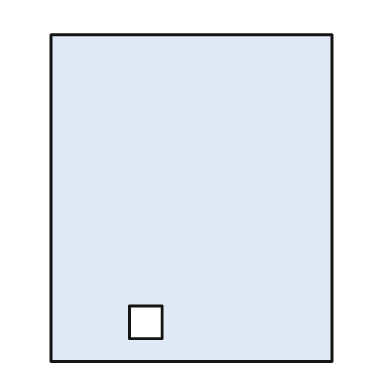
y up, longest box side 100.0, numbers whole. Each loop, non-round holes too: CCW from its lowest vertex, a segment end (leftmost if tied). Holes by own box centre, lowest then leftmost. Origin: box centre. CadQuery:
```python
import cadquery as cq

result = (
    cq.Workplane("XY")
    .moveTo(-43.0, -50.0)
    .lineTo(43.0, -50.0)
    .lineTo(43.0, 50.0)
    .lineTo(-43.0, 50.0)
    .close()
    .moveTo(-19.0, -43.0)
    .lineTo(-9.0, -43.0)
    .lineTo(-9.0, -33.0)
    .lineTo(-19.0, -33.0)
    .close()
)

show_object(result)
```